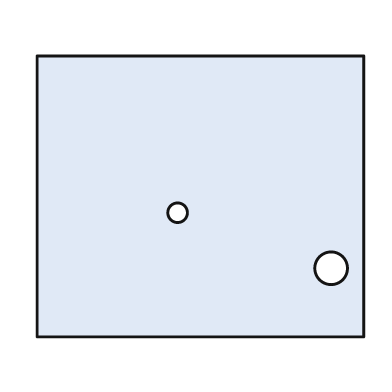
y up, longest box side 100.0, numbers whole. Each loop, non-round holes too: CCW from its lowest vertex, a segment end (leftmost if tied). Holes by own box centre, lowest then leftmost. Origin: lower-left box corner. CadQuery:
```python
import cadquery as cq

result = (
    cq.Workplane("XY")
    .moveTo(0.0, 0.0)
    .lineTo(100.0, 0.0)
    .lineTo(100.0, 86.0)
    .lineTo(0.0, 86.0)
    .close()
    .moveTo(90.0, 21.0)
    .circle(5.0)
    .moveTo(43.0, 38.0)
    .circle(3.0)
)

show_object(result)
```